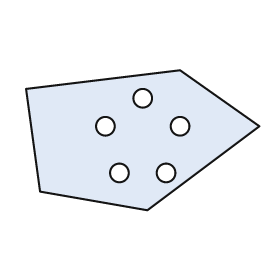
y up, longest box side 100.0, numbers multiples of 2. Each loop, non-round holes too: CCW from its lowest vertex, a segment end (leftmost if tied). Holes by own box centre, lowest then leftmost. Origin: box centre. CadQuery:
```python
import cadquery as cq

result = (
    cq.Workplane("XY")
    .moveTo(2.0, -30.0)
    .lineTo(50.0, 6.0)
    .lineTo(16.0, 30.0)
    .lineTo(-50.0, 22.0)
    .lineTo(-44.0, -22.0)
    .close()
    .moveTo(-10.0, -14.0)
    .circle(4.0)
    .moveTo(10.0, -14.0)
    .circle(4.0)
    .moveTo(-16.0, 6.0)
    .circle(4.0)
    .moveTo(16.0, 6.0)
    .circle(4.0)
    .moveTo(0.0, 18.0)
    .circle(4.0)
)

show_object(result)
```